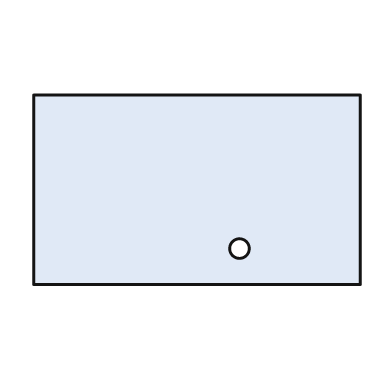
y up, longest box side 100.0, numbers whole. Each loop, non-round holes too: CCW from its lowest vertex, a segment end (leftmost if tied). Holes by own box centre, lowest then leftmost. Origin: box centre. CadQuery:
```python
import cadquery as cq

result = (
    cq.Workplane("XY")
    .moveTo(-50.0, -29.0)
    .lineTo(50.0, -29.0)
    .lineTo(50.0, 29.0)
    .lineTo(-50.0, 29.0)
    .close()
    .moveTo(13.0, -18.0)
    .circle(3.0)
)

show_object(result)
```